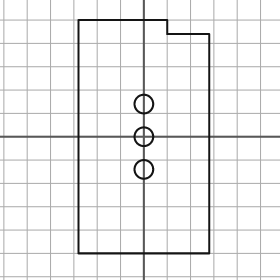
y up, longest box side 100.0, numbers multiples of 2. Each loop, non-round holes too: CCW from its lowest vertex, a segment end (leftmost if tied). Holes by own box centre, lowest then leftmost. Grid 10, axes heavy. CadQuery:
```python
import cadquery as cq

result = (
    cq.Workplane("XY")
    .moveTo(-28.0, -50.0)
    .lineTo(28.0, -50.0)
    .lineTo(28.0, 44.0)
    .lineTo(10.0, 44.0)
    .lineTo(10.0, 50.0)
    .lineTo(-28.0, 50.0)
    .close()
    .moveTo(0.0, -14.0)
    .circle(4.0)
    .moveTo(0.0, 0.0)
    .circle(4.0)
    .moveTo(0.0, 14.0)
    .circle(4.0)
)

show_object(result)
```